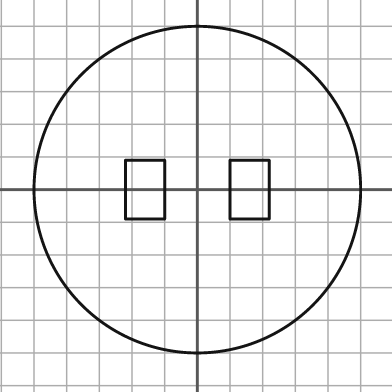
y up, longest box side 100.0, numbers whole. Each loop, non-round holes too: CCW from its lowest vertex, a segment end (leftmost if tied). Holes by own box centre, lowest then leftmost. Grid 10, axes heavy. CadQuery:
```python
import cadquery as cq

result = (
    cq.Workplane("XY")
    .moveTo(0.0, 0.0)
    .circle(50.0)
    .moveTo(-22.0, -9.0)
    .lineTo(-10.0, -9.0)
    .lineTo(-10.0, 9.0)
    .lineTo(-22.0, 9.0)
    .close()
    .moveTo(10.0, -9.0)
    .lineTo(22.0, -9.0)
    .lineTo(22.0, 9.0)
    .lineTo(10.0, 9.0)
    .close()
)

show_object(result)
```